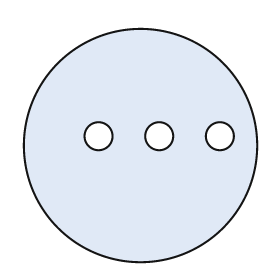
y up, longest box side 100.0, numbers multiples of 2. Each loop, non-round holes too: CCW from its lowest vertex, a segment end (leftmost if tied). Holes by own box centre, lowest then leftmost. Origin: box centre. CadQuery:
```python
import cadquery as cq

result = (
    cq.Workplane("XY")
    .moveTo(0.0, 0.0)
    .circle(50.0)
    .moveTo(-18.0, 4.0)
    .circle(6.0)
    .moveTo(8.0, 4.0)
    .circle(6.0)
    .moveTo(34.0, 4.0)
    .circle(6.0)
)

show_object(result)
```